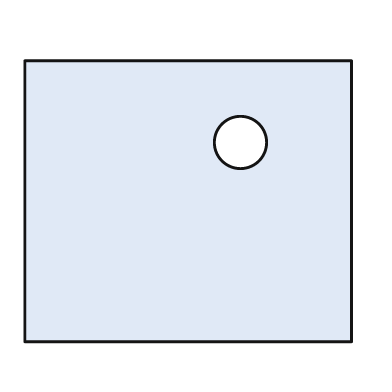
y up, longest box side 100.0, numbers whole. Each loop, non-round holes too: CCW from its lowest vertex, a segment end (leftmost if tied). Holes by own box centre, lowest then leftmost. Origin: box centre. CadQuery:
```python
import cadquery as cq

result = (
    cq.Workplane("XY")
    .moveTo(-50.0, -43.0)
    .lineTo(50.0, -43.0)
    .lineTo(50.0, 43.0)
    .lineTo(-50.0, 43.0)
    .close()
    .moveTo(16.0, 18.0)
    .circle(8.0)
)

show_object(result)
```